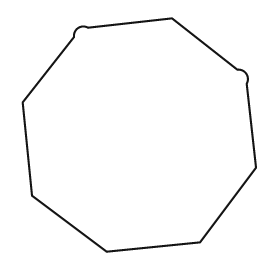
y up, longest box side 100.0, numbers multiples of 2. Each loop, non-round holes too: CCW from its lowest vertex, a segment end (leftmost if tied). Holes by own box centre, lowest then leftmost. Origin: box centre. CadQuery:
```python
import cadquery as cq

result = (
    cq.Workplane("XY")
    .moveTo(-14.0, -50.0)
    .lineTo(26.0, -46.0)
    .lineTo(50.0, -14.0)
    .lineTo(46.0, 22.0)
    .threePointArc((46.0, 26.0), (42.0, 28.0))
    .lineTo(14.0, 50.0)
    .lineTo(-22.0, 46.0)
    .threePointArc((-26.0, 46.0), (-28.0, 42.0))
    .lineTo(-50.0, 14.0)
    .lineTo(-46.0, -26.0)
    .close()
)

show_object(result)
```